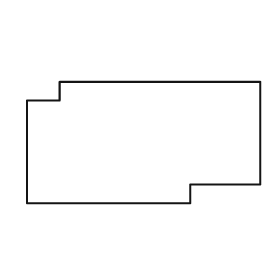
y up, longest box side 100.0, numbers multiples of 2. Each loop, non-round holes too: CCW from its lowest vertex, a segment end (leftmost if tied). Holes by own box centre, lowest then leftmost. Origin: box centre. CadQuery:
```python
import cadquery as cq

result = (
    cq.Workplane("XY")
    .moveTo(-50.0, -26.0)
    .lineTo(20.0, -26.0)
    .lineTo(20.0, -18.0)
    .lineTo(50.0, -18.0)
    .lineTo(50.0, 26.0)
    .lineTo(-36.0, 26.0)
    .lineTo(-36.0, 18.0)
    .lineTo(-50.0, 18.0)
    .close()
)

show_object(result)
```